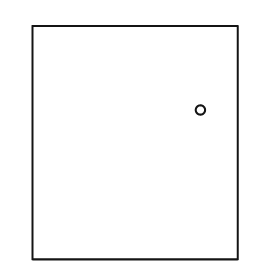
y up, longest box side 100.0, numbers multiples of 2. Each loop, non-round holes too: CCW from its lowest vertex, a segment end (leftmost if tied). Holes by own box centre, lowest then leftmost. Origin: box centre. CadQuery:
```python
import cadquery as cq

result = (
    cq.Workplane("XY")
    .moveTo(-44.0, -50.0)
    .lineTo(44.0, -50.0)
    .lineTo(44.0, 50.0)
    .lineTo(-44.0, 50.0)
    .close()
    .moveTo(28.0, 14.0)
    .circle(2.0)
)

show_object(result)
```